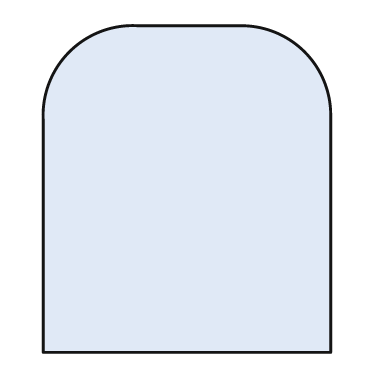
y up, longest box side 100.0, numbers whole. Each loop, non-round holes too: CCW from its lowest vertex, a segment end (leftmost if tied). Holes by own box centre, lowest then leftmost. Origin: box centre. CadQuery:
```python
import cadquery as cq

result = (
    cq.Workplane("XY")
    .moveTo(-44.0, -50.0)
    .lineTo(44.0, -50.0)
    .lineTo(44.0, 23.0)
    .threePointArc((36.0, 42.0), (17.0, 50.0))
    .lineTo(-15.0, 50.0)
    .threePointArc((-36.0, 42.0), (-44.0, 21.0))
    .close()
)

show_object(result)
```